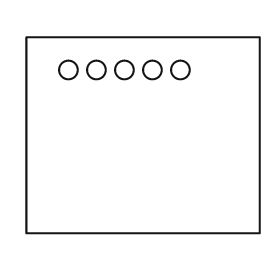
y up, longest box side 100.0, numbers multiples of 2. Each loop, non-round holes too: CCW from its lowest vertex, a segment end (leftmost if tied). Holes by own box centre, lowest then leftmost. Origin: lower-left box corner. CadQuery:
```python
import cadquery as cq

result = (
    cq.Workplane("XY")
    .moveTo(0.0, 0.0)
    .lineTo(100.0, 0.0)
    .lineTo(100.0, 84.0)
    .lineTo(0.0, 84.0)
    .close()
    .moveTo(18.0, 70.0)
    .circle(4.0)
    .moveTo(30.0, 70.0)
    .circle(4.0)
    .moveTo(42.0, 70.0)
    .circle(4.0)
    .moveTo(54.0, 70.0)
    .circle(4.0)
    .moveTo(66.0, 70.0)
    .circle(4.0)
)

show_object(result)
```